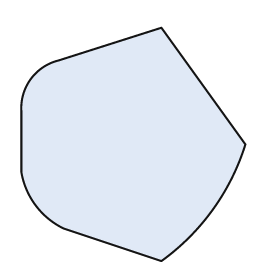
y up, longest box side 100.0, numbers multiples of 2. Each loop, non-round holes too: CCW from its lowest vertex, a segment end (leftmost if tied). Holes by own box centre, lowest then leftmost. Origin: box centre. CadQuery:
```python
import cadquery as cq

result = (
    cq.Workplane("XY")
    .moveTo(12.0, -50.0)
    .threePointArc((34.0, -28.0), (48.0, 0.0))
    .lineTo(12.0, 50.0)
    .lineTo(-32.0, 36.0)
    .threePointArc((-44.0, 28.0), (-48.0, 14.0))
    .lineTo(-48.0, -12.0)
    .threePointArc((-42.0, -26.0), (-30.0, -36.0))
    .close()
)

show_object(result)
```